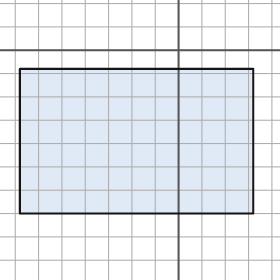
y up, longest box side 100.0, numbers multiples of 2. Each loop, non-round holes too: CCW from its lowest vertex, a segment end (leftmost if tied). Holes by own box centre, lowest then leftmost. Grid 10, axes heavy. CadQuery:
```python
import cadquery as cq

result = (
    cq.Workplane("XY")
    .moveTo(-68.0, -70.0)
    .lineTo(32.0, -70.0)
    .lineTo(32.0, -8.0)
    .lineTo(-68.0, -8.0)
    .close()
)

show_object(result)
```